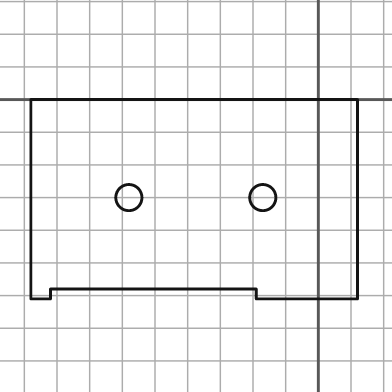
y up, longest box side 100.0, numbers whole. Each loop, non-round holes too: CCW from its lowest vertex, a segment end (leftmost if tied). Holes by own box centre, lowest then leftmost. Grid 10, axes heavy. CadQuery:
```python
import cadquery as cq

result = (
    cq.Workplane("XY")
    .moveTo(-88.0, -61.0)
    .lineTo(-82.0, -61.0)
    .lineTo(-82.0, -58.0)
    .lineTo(-19.0, -58.0)
    .lineTo(-19.0, -61.0)
    .lineTo(12.0, -61.0)
    .lineTo(12.0, 0.0)
    .lineTo(-88.0, 0.0)
    .close()
    .moveTo(-58.0, -30.0)
    .circle(4.0)
    .moveTo(-17.0, -30.0)
    .circle(4.0)
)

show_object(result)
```